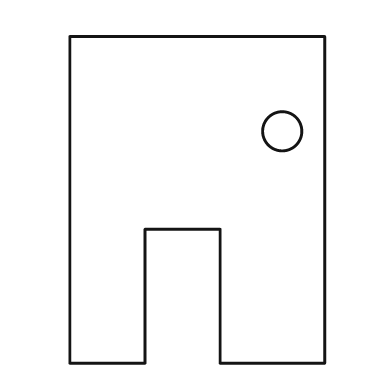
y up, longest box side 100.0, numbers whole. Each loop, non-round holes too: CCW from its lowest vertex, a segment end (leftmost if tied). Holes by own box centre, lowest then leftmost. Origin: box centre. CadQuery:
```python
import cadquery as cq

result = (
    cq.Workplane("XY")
    .moveTo(-39.0, -50.0)
    .lineTo(-16.0, -50.0)
    .lineTo(-16.0, -9.0)
    .lineTo(7.0, -9.0)
    .lineTo(7.0, -50.0)
    .lineTo(39.0, -50.0)
    .lineTo(39.0, 50.0)
    .lineTo(-39.0, 50.0)
    .close()
    .moveTo(26.0, 21.0)
    .circle(6.0)
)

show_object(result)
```